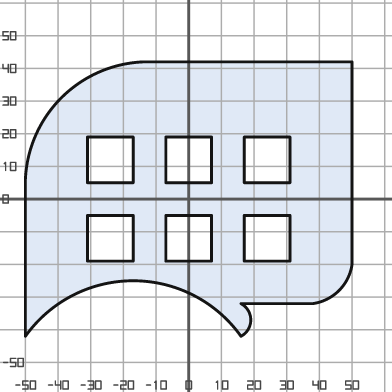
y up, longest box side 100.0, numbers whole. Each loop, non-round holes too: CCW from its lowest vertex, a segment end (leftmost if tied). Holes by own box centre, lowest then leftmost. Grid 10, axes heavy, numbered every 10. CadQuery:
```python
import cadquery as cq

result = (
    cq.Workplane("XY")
    .moveTo(-50.0, -42.0)
    .threePointArc((-17.0, -25.0), (16.0, -42.0))
    .threePointArc((19.0, -37.0), (16.0, -32.0))
    .lineTo(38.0, -32.0)
    .threePointArc((46.0, -28.0), (50.0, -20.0))
    .lineTo(50.0, 42.0)
    .lineTo(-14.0, 42.0)
    .threePointArc((-39.0, 31.0), (-50.0, 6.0))
    .close()
    .moveTo(-31.0, -19.0)
    .lineTo(-17.0, -19.0)
    .lineTo(-17.0, -5.0)
    .lineTo(-31.0, -5.0)
    .close()
    .moveTo(-7.0, -19.0)
    .lineTo(7.0, -19.0)
    .lineTo(7.0, -5.0)
    .lineTo(-7.0, -5.0)
    .close()
    .moveTo(17.0, -19.0)
    .lineTo(31.0, -19.0)
    .lineTo(31.0, -5.0)
    .lineTo(17.0, -5.0)
    .close()
    .moveTo(-31.0, 5.0)
    .lineTo(-17.0, 5.0)
    .lineTo(-17.0, 19.0)
    .lineTo(-31.0, 19.0)
    .close()
    .moveTo(-7.0, 5.0)
    .lineTo(7.0, 5.0)
    .lineTo(7.0, 19.0)
    .lineTo(-7.0, 19.0)
    .close()
    .moveTo(17.0, 5.0)
    .lineTo(31.0, 5.0)
    .lineTo(31.0, 19.0)
    .lineTo(17.0, 19.0)
    .close()
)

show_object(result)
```